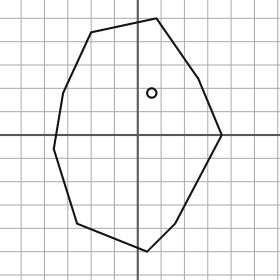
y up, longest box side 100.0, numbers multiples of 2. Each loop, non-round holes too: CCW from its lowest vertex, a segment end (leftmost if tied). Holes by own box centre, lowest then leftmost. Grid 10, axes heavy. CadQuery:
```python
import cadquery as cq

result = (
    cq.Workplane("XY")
    .moveTo(4.0, -50.0)
    .lineTo(16.0, -38.0)
    .lineTo(36.0, 0.0)
    .lineTo(26.0, 24.0)
    .lineTo(8.0, 50.0)
    .lineTo(-20.0, 44.0)
    .lineTo(-32.0, 18.0)
    .lineTo(-36.0, -6.0)
    .lineTo(-26.0, -38.0)
    .close()
    .moveTo(6.0, 18.0)
    .circle(2.0)
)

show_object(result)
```